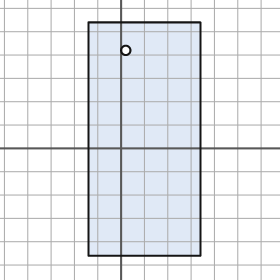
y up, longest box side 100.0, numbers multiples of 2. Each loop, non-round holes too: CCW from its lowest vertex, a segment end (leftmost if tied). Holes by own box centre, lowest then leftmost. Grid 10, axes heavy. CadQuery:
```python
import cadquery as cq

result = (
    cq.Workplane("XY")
    .moveTo(-14.0, -46.0)
    .lineTo(34.0, -46.0)
    .lineTo(34.0, 54.0)
    .lineTo(-14.0, 54.0)
    .close()
    .moveTo(2.0, 42.0)
    .circle(2.0)
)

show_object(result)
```